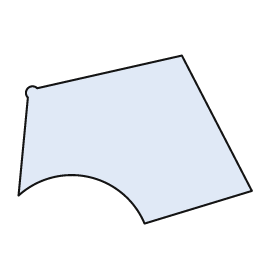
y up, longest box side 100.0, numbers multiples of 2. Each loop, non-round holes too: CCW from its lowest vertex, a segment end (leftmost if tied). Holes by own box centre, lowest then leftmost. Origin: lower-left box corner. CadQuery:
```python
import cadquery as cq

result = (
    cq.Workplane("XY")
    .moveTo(54.0, 0.0)
    .lineTo(100.0, 14.0)
    .lineTo(70.0, 72.0)
    .lineTo(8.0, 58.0)
    .threePointArc((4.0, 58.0), (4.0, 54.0))
    .lineTo(0.0, 12.0)
    .threePointArc((30.0, 20.0), (54.0, 0.0))
    .close()
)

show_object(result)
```